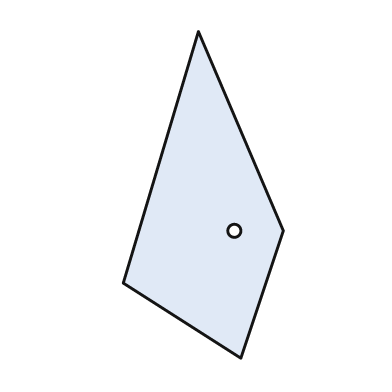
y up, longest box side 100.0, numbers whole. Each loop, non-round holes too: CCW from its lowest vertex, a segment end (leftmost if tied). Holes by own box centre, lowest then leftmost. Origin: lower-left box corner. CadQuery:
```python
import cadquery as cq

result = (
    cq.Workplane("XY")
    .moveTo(36.0, 0.0)
    .lineTo(49.0, 39.0)
    .lineTo(23.0, 100.0)
    .lineTo(0.0, 23.0)
    .close()
    .moveTo(34.0, 39.0)
    .circle(2.0)
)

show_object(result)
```